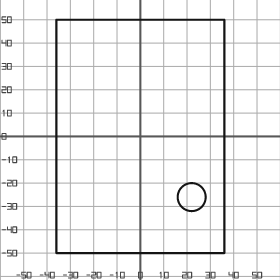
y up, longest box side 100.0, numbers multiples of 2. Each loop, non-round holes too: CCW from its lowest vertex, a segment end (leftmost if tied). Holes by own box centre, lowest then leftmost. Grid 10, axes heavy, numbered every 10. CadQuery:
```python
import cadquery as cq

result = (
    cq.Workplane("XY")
    .moveTo(-36.0, -50.0)
    .lineTo(36.0, -50.0)
    .lineTo(36.0, 50.0)
    .lineTo(-36.0, 50.0)
    .close()
    .moveTo(22.0, -26.0)
    .circle(6.0)
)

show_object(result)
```